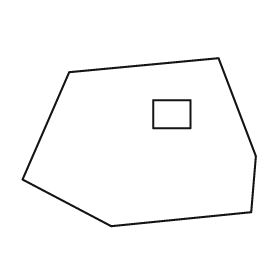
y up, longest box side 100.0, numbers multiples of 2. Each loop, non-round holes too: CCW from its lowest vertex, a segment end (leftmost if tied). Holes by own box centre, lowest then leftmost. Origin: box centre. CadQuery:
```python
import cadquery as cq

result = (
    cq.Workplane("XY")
    .moveTo(-12.0, -36.0)
    .lineTo(48.0, -30.0)
    .lineTo(50.0, -6.0)
    .lineTo(34.0, 36.0)
    .lineTo(-30.0, 30.0)
    .lineTo(-50.0, -16.0)
    .close()
    .moveTo(6.0, 6.0)
    .lineTo(22.0, 6.0)
    .lineTo(22.0, 18.0)
    .lineTo(6.0, 18.0)
    .close()
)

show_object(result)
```